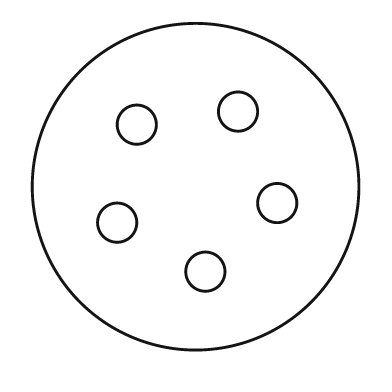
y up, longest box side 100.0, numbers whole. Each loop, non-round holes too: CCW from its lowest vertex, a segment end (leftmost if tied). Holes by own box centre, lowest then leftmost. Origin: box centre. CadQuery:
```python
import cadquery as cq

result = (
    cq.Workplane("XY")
    .moveTo(0.0, 0.0)
    .circle(50.0)
    .moveTo(3.0, -26.0)
    .circle(6.0)
    .moveTo(-24.0, -11.0)
    .circle(6.0)
    .moveTo(25.0, -5.0)
    .circle(6.0)
    .moveTo(-18.0, 19.0)
    .circle(6.0)
    .moveTo(13.0, 23.0)
    .circle(6.0)
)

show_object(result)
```